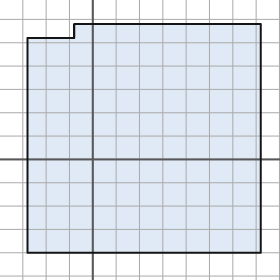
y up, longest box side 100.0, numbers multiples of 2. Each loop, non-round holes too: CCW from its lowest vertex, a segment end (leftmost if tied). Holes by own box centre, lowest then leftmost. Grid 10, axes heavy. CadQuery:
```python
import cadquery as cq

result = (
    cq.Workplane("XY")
    .moveTo(-28.0, -40.0)
    .lineTo(72.0, -40.0)
    .lineTo(72.0, 58.0)
    .lineTo(-8.0, 58.0)
    .lineTo(-8.0, 52.0)
    .lineTo(-28.0, 52.0)
    .close()
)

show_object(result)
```